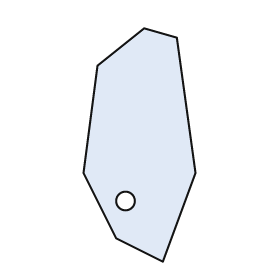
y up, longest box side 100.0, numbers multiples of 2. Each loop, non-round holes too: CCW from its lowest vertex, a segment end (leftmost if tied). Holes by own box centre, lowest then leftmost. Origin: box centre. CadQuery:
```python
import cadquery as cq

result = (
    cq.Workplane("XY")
    .moveTo(10.0, -50.0)
    .lineTo(24.0, -12.0)
    .lineTo(16.0, 46.0)
    .lineTo(2.0, 50.0)
    .lineTo(-18.0, 34.0)
    .lineTo(-24.0, -12.0)
    .lineTo(-10.0, -40.0)
    .close()
    .moveTo(-6.0, -24.0)
    .circle(4.0)
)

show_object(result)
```